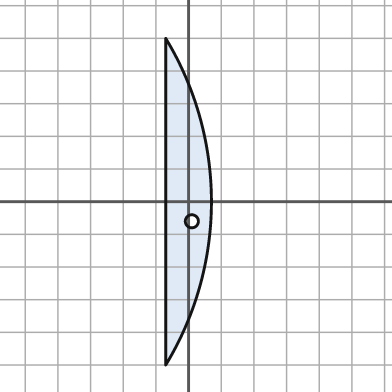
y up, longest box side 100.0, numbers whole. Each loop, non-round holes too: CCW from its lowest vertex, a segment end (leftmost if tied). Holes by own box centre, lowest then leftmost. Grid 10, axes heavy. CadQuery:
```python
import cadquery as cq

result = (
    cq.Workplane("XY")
    .moveTo(-7.0, -50.0)
    .threePointArc((7.0, 0.0), (-7.0, 50.0))
    .close()
    .moveTo(1.0, -6.0)
    .circle(2.0)
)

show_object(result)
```